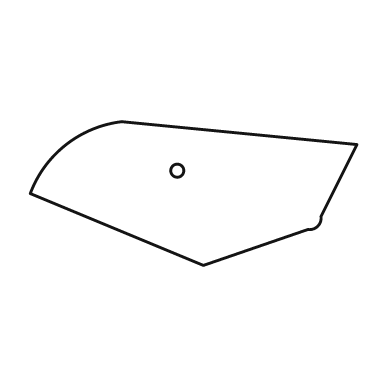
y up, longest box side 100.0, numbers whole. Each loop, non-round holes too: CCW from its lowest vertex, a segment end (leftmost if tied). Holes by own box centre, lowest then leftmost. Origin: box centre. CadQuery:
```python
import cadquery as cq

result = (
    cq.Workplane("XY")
    .moveTo(3.0, -22.0)
    .lineTo(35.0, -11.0)
    .threePointArc((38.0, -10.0), (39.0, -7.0))
    .lineTo(50.0, 15.0)
    .lineTo(-22.0, 22.0)
    .threePointArc((-39.0, 15.0), (-50.0, 0.0))
    .close()
    .moveTo(-5.0, 7.0)
    .circle(2.0)
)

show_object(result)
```